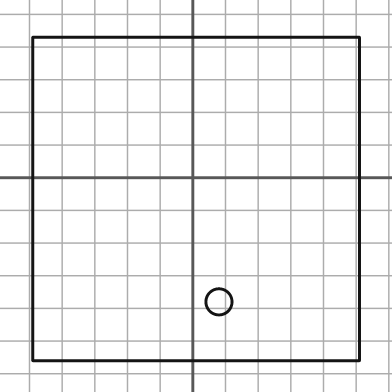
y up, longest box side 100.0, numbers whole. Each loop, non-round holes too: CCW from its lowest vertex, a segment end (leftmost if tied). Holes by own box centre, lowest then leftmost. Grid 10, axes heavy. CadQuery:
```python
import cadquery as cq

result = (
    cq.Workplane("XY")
    .moveTo(-49.0, -56.0)
    .lineTo(51.0, -56.0)
    .lineTo(51.0, 43.0)
    .lineTo(-49.0, 43.0)
    .close()
    .moveTo(8.0, -38.0)
    .circle(4.0)
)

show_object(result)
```